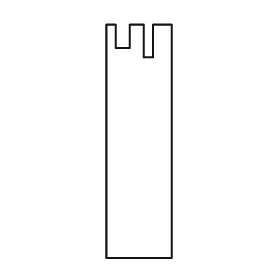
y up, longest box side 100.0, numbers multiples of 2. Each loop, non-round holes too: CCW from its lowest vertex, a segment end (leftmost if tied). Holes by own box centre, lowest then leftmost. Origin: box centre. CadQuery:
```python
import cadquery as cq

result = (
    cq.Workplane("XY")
    .moveTo(-14.0, -50.0)
    .lineTo(14.0, -50.0)
    .lineTo(14.0, 50.0)
    .lineTo(6.0, 50.0)
    .lineTo(6.0, 36.0)
    .lineTo(2.0, 36.0)
    .lineTo(2.0, 50.0)
    .lineTo(-4.0, 50.0)
    .lineTo(-4.0, 40.0)
    .lineTo(-10.0, 40.0)
    .lineTo(-10.0, 50.0)
    .lineTo(-14.0, 50.0)
    .close()
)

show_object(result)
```